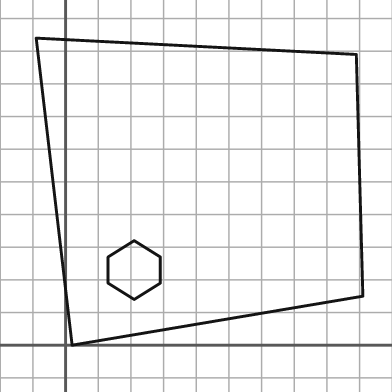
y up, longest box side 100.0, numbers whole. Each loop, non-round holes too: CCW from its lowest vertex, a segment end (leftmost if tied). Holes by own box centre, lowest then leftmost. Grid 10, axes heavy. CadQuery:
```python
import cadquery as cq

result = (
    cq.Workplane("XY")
    .moveTo(2.0, 0.0)
    .lineTo(91.0, 15.0)
    .lineTo(89.0, 89.0)
    .lineTo(-9.0, 94.0)
    .close()
    .moveTo(21.0, 14.0)
    .lineTo(29.0, 19.0)
    .lineTo(29.0, 27.0)
    .lineTo(21.0, 32.0)
    .lineTo(13.0, 27.0)
    .lineTo(13.0, 19.0)
    .close()
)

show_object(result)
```